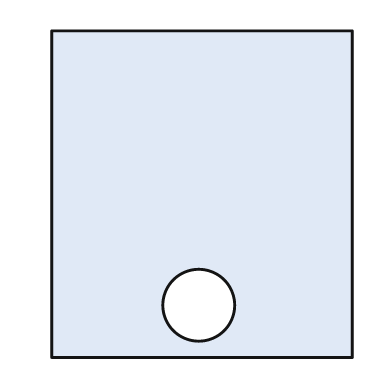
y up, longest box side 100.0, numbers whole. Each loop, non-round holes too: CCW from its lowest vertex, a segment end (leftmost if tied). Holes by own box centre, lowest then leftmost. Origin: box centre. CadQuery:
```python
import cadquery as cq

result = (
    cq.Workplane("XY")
    .moveTo(-46.0, -50.0)
    .lineTo(46.0, -50.0)
    .lineTo(46.0, 50.0)
    .lineTo(-46.0, 50.0)
    .close()
    .moveTo(-1.0, -34.0)
    .circle(11.0)
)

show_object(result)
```